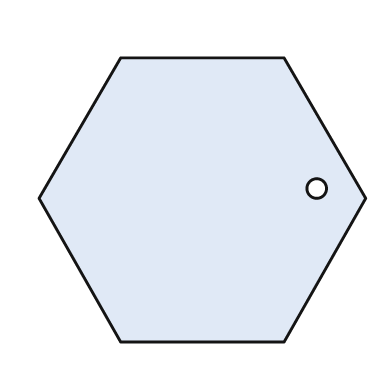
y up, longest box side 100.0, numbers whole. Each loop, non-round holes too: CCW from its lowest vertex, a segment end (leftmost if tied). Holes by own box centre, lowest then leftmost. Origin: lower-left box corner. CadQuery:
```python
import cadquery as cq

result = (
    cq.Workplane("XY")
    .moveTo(25.0, 0.0)
    .lineTo(75.0, 0.0)
    .lineTo(100.0, 44.0)
    .lineTo(75.0, 87.0)
    .lineTo(25.0, 87.0)
    .lineTo(0.0, 44.0)
    .close()
    .moveTo(85.0, 47.0)
    .circle(3.0)
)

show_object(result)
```